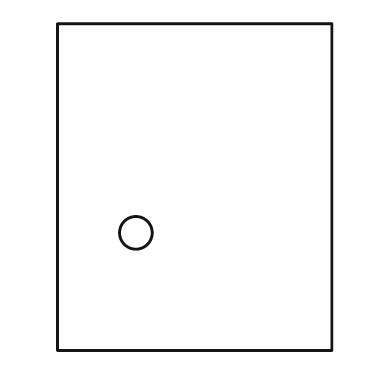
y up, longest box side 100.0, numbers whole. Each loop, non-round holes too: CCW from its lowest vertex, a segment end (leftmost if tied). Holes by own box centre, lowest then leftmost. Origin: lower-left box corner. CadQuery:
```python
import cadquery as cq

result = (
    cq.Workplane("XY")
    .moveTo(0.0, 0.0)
    .lineTo(84.0, 0.0)
    .lineTo(84.0, 100.0)
    .lineTo(0.0, 100.0)
    .close()
    .moveTo(24.0, 36.0)
    .circle(5.0)
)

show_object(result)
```